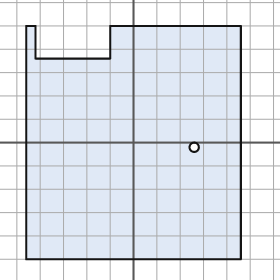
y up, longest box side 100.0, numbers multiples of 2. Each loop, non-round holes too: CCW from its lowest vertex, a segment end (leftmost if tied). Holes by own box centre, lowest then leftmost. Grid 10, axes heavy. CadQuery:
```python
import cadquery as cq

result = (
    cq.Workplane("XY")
    .moveTo(-46.0, -50.0)
    .lineTo(46.0, -50.0)
    .lineTo(46.0, 50.0)
    .lineTo(-10.0, 50.0)
    .lineTo(-10.0, 36.0)
    .lineTo(-42.0, 36.0)
    .lineTo(-42.0, 50.0)
    .lineTo(-46.0, 50.0)
    .close()
    .moveTo(26.0, -2.0)
    .circle(2.0)
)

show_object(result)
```